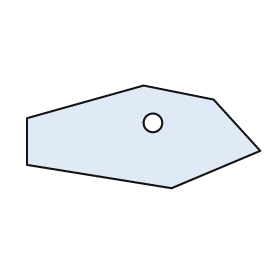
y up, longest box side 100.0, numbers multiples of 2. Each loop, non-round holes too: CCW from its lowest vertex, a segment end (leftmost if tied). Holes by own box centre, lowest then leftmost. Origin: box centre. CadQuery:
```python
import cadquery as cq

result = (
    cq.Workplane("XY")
    .moveTo(12.0, -22.0)
    .lineTo(50.0, -6.0)
    .lineTo(30.0, 16.0)
    .lineTo(0.0, 22.0)
    .lineTo(-50.0, 8.0)
    .lineTo(-50.0, -12.0)
    .close()
    .moveTo(4.0, 6.0)
    .circle(4.0)
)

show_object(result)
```